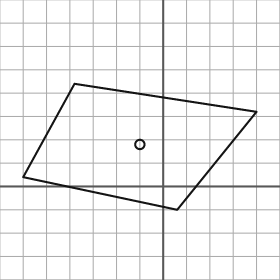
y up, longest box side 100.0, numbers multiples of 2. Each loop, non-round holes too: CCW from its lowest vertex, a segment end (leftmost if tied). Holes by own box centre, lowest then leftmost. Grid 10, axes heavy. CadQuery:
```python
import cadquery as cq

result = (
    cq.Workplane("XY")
    .moveTo(6.0, -10.0)
    .lineTo(40.0, 32.0)
    .lineTo(-38.0, 44.0)
    .lineTo(-60.0, 4.0)
    .close()
    .moveTo(-10.0, 18.0)
    .circle(2.0)
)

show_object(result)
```